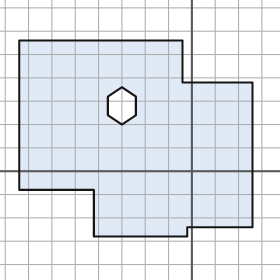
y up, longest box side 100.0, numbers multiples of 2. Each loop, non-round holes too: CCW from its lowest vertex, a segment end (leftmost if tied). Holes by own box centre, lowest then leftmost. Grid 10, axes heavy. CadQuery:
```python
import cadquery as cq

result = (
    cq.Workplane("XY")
    .moveTo(-42.0, -28.0)
    .lineTo(-2.0, -28.0)
    .lineTo(-2.0, -24.0)
    .lineTo(26.0, -24.0)
    .lineTo(26.0, 38.0)
    .lineTo(-4.0, 38.0)
    .lineTo(-4.0, 56.0)
    .lineTo(-74.0, 56.0)
    .lineTo(-74.0, -8.0)
    .lineTo(-42.0, -8.0)
    .close()
    .moveTo(-30.0, 20.0)
    .lineTo(-24.0, 24.0)
    .lineTo(-24.0, 32.0)
    .lineTo(-30.0, 36.0)
    .lineTo(-36.0, 32.0)
    .lineTo(-36.0, 24.0)
    .close()
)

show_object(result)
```